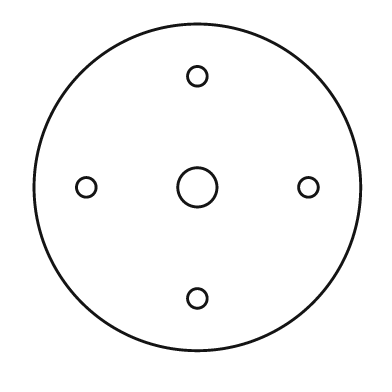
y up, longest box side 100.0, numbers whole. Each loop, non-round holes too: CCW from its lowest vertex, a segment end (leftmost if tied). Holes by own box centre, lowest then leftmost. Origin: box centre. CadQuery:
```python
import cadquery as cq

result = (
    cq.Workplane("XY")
    .moveTo(0.0, 0.0)
    .circle(50.0)
    .moveTo(0.0, -34.0)
    .circle(3.0)
    .moveTo(-34.0, 0.0)
    .circle(3.0)
    .moveTo(0.0, 0.0)
    .circle(6.0)
    .moveTo(34.0, 0.0)
    .circle(3.0)
    .moveTo(0.0, 34.0)
    .circle(3.0)
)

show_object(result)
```